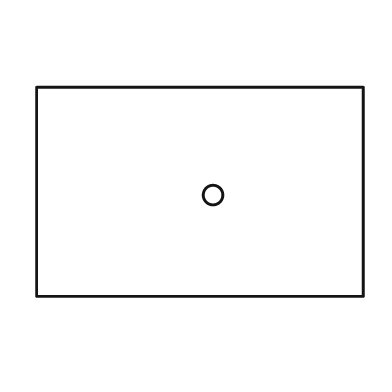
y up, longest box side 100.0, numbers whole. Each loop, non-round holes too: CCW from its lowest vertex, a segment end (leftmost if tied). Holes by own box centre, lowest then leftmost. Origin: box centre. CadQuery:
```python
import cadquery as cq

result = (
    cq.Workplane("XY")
    .moveTo(-50.0, -32.0)
    .lineTo(50.0, -32.0)
    .lineTo(50.0, 32.0)
    .lineTo(-50.0, 32.0)
    .close()
    .moveTo(4.0, -1.0)
    .circle(3.0)
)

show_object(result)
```